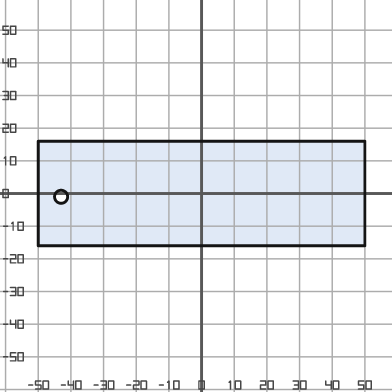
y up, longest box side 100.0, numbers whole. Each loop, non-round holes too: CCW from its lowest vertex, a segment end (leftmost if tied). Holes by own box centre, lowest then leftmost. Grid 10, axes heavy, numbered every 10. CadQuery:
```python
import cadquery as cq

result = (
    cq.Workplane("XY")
    .moveTo(-50.0, -16.0)
    .lineTo(50.0, -16.0)
    .lineTo(50.0, 16.0)
    .lineTo(-50.0, 16.0)
    .close()
    .moveTo(-43.0, -1.0)
    .circle(2.0)
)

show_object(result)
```